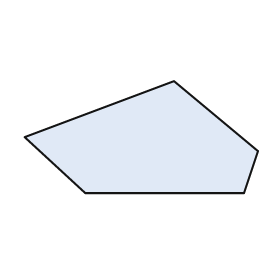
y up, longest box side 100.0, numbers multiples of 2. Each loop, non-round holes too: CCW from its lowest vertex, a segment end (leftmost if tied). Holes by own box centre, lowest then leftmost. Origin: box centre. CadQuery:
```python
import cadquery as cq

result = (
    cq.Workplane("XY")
    .moveTo(-24.0, -24.0)
    .lineTo(44.0, -24.0)
    .lineTo(50.0, -6.0)
    .lineTo(14.0, 24.0)
    .lineTo(-50.0, 0.0)
    .close()
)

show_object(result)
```